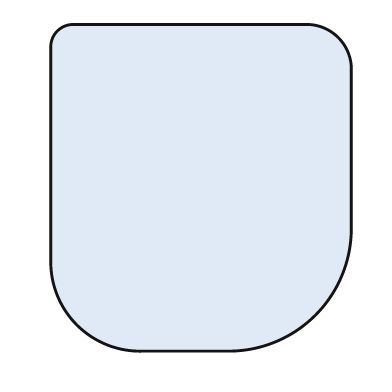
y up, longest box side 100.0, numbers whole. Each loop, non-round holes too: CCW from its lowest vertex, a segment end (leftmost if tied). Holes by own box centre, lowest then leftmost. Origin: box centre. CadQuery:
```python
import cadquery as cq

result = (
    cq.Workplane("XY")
    .moveTo(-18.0, -50.0)
    .lineTo(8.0, -50.0)
    .threePointArc((35.0, -39.0), (46.0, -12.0))
    .lineTo(46.0, 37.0)
    .threePointArc((42.0, 46.0), (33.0, 50.0))
    .lineTo(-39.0, 50.0)
    .threePointArc((-44.0, 48.0), (-46.0, 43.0))
    .lineTo(-46.0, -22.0)
    .threePointArc((-38.0, -42.0), (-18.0, -50.0))
    .close()
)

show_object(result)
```